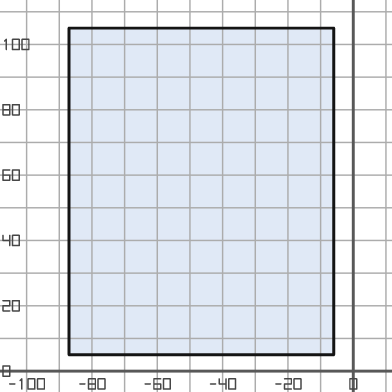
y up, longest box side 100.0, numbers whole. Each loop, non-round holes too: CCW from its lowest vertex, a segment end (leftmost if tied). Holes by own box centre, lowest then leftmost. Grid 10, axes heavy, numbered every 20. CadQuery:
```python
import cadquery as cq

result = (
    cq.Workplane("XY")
    .moveTo(-87.0, 5.0)
    .lineTo(-6.0, 5.0)
    .lineTo(-6.0, 105.0)
    .lineTo(-87.0, 105.0)
    .close()
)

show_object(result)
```